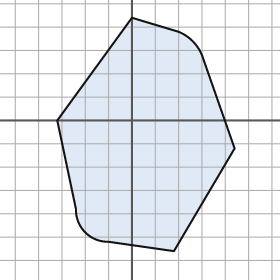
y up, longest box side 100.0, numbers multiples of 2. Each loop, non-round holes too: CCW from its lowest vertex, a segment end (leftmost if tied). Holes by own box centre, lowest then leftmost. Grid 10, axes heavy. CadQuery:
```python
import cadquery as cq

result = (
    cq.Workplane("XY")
    .moveTo(18.0, -56.0)
    .lineTo(44.0, -12.0)
    .lineTo(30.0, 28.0)
    .threePointArc((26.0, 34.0), (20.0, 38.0))
    .lineTo(0.0, 44.0)
    .lineTo(-32.0, 0.0)
    .lineTo(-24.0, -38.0)
    .threePointArc((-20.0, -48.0), (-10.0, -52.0))
    .close()
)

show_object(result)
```